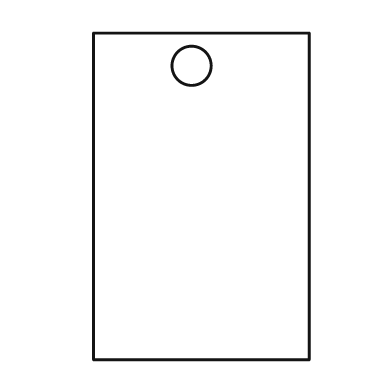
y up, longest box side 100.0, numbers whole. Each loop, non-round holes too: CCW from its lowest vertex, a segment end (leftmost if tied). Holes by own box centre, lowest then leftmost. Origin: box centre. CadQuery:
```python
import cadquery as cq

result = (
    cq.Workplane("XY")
    .moveTo(-33.0, -50.0)
    .lineTo(33.0, -50.0)
    .lineTo(33.0, 50.0)
    .lineTo(-33.0, 50.0)
    .close()
    .moveTo(-3.0, 40.0)
    .circle(6.0)
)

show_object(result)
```